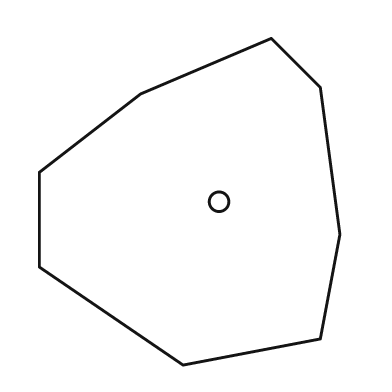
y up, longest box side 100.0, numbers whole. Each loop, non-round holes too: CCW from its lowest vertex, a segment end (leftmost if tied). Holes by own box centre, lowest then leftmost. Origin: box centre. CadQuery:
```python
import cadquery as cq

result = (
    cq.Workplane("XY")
    .moveTo(-2.0, -50.0)
    .lineTo(40.0, -42.0)
    .lineTo(46.0, -10.0)
    .lineTo(40.0, 35.0)
    .lineTo(25.0, 50.0)
    .lineTo(-15.0, 33.0)
    .lineTo(-46.0, 9.0)
    .lineTo(-46.0, -20.0)
    .close()
    .moveTo(9.0, 0.0)
    .circle(3.0)
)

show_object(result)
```